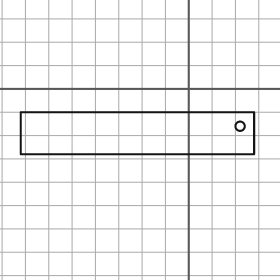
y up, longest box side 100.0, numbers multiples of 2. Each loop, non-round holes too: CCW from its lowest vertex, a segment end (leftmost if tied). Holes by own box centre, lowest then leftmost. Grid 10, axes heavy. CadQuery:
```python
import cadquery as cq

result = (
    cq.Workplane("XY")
    .moveTo(-72.0, -28.0)
    .lineTo(28.0, -28.0)
    .lineTo(28.0, -10.0)
    .lineTo(-72.0, -10.0)
    .close()
    .moveTo(22.0, -16.0)
    .circle(2.0)
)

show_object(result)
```